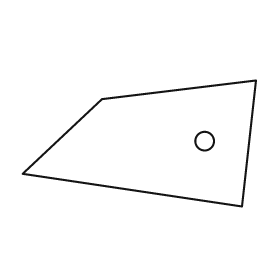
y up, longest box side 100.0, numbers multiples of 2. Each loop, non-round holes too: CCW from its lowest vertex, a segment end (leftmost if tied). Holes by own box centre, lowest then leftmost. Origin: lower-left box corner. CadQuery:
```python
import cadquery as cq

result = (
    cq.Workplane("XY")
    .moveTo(94.0, 0.0)
    .lineTo(100.0, 54.0)
    .lineTo(34.0, 46.0)
    .lineTo(0.0, 14.0)
    .close()
    .moveTo(78.0, 28.0)
    .circle(4.0)
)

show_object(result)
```